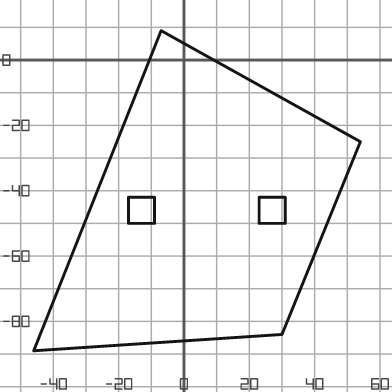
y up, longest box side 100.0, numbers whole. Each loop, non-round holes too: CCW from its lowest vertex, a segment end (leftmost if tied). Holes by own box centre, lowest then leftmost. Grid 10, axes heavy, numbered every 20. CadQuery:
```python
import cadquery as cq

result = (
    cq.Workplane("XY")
    .moveTo(-46.0, -89.0)
    .lineTo(30.0, -84.0)
    .lineTo(54.0, -25.0)
    .lineTo(-7.0, 9.0)
    .close()
    .moveTo(-17.0, -50.0)
    .lineTo(-9.0, -50.0)
    .lineTo(-9.0, -42.0)
    .lineTo(-17.0, -42.0)
    .close()
    .moveTo(23.0, -50.0)
    .lineTo(31.0, -50.0)
    .lineTo(31.0, -42.0)
    .lineTo(23.0, -42.0)
    .close()
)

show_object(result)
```